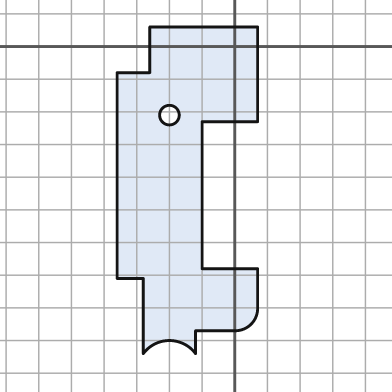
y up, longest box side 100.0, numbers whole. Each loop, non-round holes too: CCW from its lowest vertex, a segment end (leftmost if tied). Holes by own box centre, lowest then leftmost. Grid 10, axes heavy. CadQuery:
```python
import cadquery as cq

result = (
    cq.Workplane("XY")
    .moveTo(-28.0, -94.0)
    .threePointArc((-20.0, -90.0), (-12.0, -94.0))
    .lineTo(-12.0, -87.0)
    .lineTo(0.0, -87.0)
    .threePointArc((5.0, -85.0), (7.0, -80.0))
    .lineTo(7.0, -68.0)
    .lineTo(-10.0, -68.0)
    .lineTo(-10.0, -23.0)
    .lineTo(7.0, -23.0)
    .lineTo(7.0, 6.0)
    .lineTo(-26.0, 6.0)
    .lineTo(-26.0, -8.0)
    .lineTo(-36.0, -8.0)
    .lineTo(-36.0, -71.0)
    .lineTo(-28.0, -71.0)
    .close()
    .moveTo(-20.0, -21.0)
    .circle(3.0)
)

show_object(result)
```